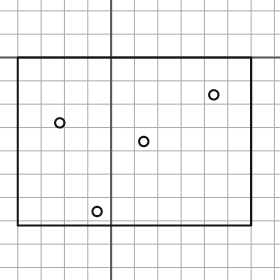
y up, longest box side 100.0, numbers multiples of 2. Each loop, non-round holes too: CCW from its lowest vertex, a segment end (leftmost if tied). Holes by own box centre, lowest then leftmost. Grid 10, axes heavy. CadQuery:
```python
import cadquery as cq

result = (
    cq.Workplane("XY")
    .moveTo(-40.0, -72.0)
    .lineTo(60.0, -72.0)
    .lineTo(60.0, 0.0)
    .lineTo(-40.0, 0.0)
    .close()
    .moveTo(-6.0, -66.0)
    .circle(2.0)
    .moveTo(14.0, -36.0)
    .circle(2.0)
    .moveTo(-22.0, -28.0)
    .circle(2.0)
    .moveTo(44.0, -16.0)
    .circle(2.0)
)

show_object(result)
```